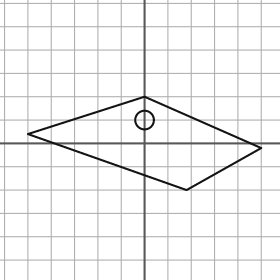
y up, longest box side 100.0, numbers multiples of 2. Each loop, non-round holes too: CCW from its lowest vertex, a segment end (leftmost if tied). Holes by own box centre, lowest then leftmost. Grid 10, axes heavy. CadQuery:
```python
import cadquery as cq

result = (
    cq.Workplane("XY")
    .moveTo(18.0, -20.0)
    .lineTo(50.0, -2.0)
    .lineTo(0.0, 20.0)
    .lineTo(-50.0, 4.0)
    .close()
    .moveTo(0.0, 10.0)
    .circle(4.0)
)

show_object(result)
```